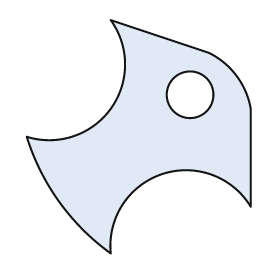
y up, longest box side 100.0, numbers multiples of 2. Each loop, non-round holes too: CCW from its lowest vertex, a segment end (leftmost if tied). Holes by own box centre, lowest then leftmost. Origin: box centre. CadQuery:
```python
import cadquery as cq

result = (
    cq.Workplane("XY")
    .moveTo(-12.0, -50.0)
    .threePointArc((10.0, -16.0), (48.0, -30.0))
    .lineTo(48.0, 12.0)
    .threePointArc((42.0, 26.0), (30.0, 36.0))
    .lineTo(-12.0, 50.0)
    .threePointArc((-12.0, 12.0), (-48.0, 0.0))
    .threePointArc((-34.0, -28.0), (-12.0, -50.0))
    .close()
    .moveTo(22.0, 18.0)
    .circle(10.0)
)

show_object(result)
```